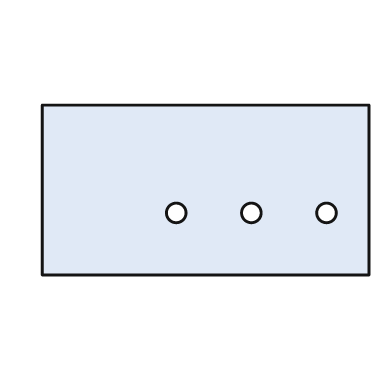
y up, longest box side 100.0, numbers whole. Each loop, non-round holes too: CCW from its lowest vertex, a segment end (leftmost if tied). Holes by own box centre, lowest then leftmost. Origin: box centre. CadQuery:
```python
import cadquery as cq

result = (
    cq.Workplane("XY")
    .moveTo(-50.0, -26.0)
    .lineTo(50.0, -26.0)
    .lineTo(50.0, 26.0)
    .lineTo(-50.0, 26.0)
    .close()
    .moveTo(-9.0, -7.0)
    .circle(3.0)
    .moveTo(14.0, -7.0)
    .circle(3.0)
    .moveTo(37.0, -7.0)
    .circle(3.0)
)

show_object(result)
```